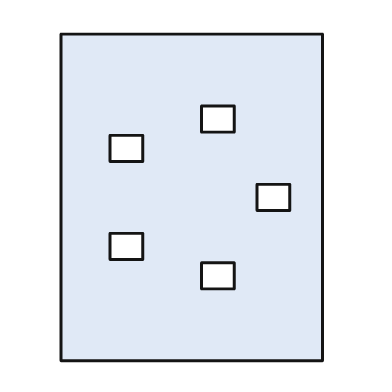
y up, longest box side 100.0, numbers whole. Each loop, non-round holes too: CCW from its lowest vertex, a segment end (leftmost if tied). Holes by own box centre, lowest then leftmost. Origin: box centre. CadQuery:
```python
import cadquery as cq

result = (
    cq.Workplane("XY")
    .moveTo(-40.0, -50.0)
    .lineTo(40.0, -50.0)
    .lineTo(40.0, 50.0)
    .lineTo(-40.0, 50.0)
    .close()
    .moveTo(3.0, -28.0)
    .lineTo(13.0, -28.0)
    .lineTo(13.0, -20.0)
    .lineTo(3.0, -20.0)
    .close()
    .moveTo(-25.0, -19.0)
    .lineTo(-15.0, -19.0)
    .lineTo(-15.0, -11.0)
    .lineTo(-25.0, -11.0)
    .close()
    .moveTo(20.0, -4.0)
    .lineTo(30.0, -4.0)
    .lineTo(30.0, 4.0)
    .lineTo(20.0, 4.0)
    .close()
    .moveTo(-25.0, 11.0)
    .lineTo(-15.0, 11.0)
    .lineTo(-15.0, 19.0)
    .lineTo(-25.0, 19.0)
    .close()
    .moveTo(3.0, 20.0)
    .lineTo(13.0, 20.0)
    .lineTo(13.0, 28.0)
    .lineTo(3.0, 28.0)
    .close()
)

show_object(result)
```